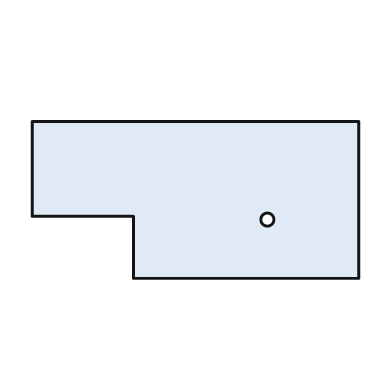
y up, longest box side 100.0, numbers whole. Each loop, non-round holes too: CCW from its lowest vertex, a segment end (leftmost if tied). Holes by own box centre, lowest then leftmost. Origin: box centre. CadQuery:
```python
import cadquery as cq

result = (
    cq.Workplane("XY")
    .moveTo(-19.0, -24.0)
    .lineTo(50.0, -24.0)
    .lineTo(50.0, 24.0)
    .lineTo(-50.0, 24.0)
    .lineTo(-50.0, -5.0)
    .lineTo(-19.0, -5.0)
    .close()
    .moveTo(22.0, -6.0)
    .circle(2.0)
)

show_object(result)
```